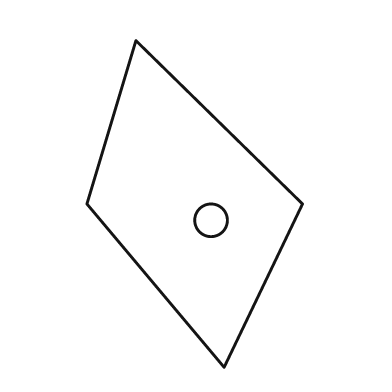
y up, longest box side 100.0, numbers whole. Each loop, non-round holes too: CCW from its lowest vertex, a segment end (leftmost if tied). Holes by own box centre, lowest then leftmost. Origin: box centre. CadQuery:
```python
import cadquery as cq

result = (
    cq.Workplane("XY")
    .moveTo(9.0, -50.0)
    .lineTo(33.0, 0.0)
    .lineTo(-18.0, 50.0)
    .lineTo(-33.0, 0.0)
    .close()
    .moveTo(5.0, -5.0)
    .circle(5.0)
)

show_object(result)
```